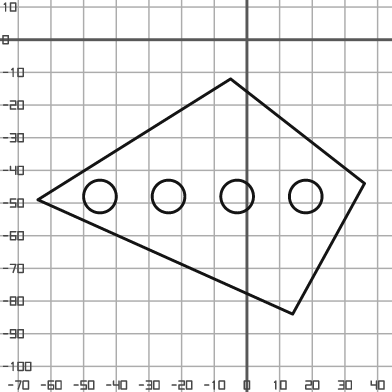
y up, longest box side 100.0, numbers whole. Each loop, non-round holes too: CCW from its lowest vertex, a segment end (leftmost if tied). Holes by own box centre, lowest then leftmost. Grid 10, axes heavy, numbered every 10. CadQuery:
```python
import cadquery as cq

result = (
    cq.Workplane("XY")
    .moveTo(14.0, -84.0)
    .lineTo(36.0, -44.0)
    .lineTo(-5.0, -12.0)
    .lineTo(-64.0, -49.0)
    .close()
    .moveTo(-45.0, -48.0)
    .circle(5.0)
    .moveTo(-24.0, -48.0)
    .circle(5.0)
    .moveTo(-3.0, -48.0)
    .circle(5.0)
    .moveTo(18.0, -48.0)
    .circle(5.0)
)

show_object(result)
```